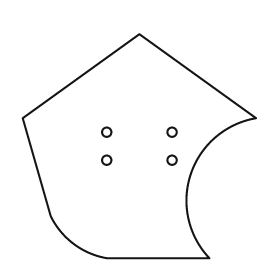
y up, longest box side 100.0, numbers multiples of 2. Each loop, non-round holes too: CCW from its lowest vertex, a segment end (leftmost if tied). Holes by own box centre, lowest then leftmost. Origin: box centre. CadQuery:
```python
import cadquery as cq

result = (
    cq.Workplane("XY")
    .moveTo(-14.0, -48.0)
    .lineTo(30.0, -48.0)
    .threePointArc((22.0, -12.0), (50.0, 12.0))
    .lineTo(0.0, 48.0)
    .lineTo(-50.0, 12.0)
    .lineTo(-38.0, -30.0)
    .threePointArc((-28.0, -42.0), (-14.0, -48.0))
    .close()
    .moveTo(-14.0, -6.0)
    .circle(2.0)
    .moveTo(14.0, -6.0)
    .circle(2.0)
    .moveTo(-14.0, 6.0)
    .circle(2.0)
    .moveTo(14.0, 6.0)
    .circle(2.0)
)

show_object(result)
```